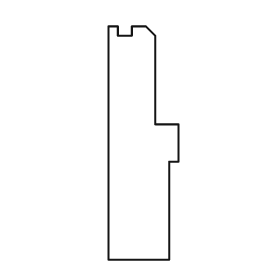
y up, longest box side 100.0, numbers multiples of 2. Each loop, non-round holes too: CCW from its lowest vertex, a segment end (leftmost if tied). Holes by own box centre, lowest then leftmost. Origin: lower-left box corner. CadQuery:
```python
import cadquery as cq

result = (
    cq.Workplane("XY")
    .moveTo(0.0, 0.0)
    .lineTo(26.0, 0.0)
    .lineTo(26.0, 42.0)
    .lineTo(30.0, 42.0)
    .lineTo(30.0, 58.0)
    .lineTo(20.0, 58.0)
    .lineTo(20.0, 96.0)
    .lineTo(16.0, 100.0)
    .lineTo(10.0, 100.0)
    .lineTo(10.0, 96.0)
    .lineTo(4.0, 96.0)
    .lineTo(4.0, 100.0)
    .lineTo(0.0, 100.0)
    .close()
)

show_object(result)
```